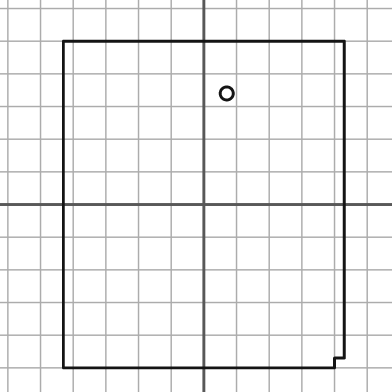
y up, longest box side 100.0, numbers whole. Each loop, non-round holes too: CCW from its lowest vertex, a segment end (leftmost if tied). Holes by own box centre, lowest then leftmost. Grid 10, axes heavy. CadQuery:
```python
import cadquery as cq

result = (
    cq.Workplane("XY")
    .moveTo(-43.0, -50.0)
    .lineTo(40.0, -50.0)
    .lineTo(40.0, -47.0)
    .lineTo(43.0, -47.0)
    .lineTo(43.0, 50.0)
    .lineTo(-43.0, 50.0)
    .close()
    .moveTo(7.0, 34.0)
    .circle(2.0)
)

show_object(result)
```